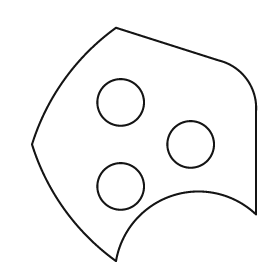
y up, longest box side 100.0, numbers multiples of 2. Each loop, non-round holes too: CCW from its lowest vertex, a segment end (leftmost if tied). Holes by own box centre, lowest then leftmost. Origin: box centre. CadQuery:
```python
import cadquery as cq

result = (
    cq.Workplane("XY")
    .moveTo(-12.0, -50.0)
    .threePointArc((12.0, -22.0), (48.0, -30.0))
    .lineTo(48.0, 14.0)
    .threePointArc((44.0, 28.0), (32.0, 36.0))
    .lineTo(-12.0, 50.0)
    .threePointArc((-34.0, 28.0), (-48.0, 0.0))
    .threePointArc((-34.0, -28.0), (-12.0, -50.0))
    .close()
    .moveTo(-10.0, -18.0)
    .circle(10.0)
    .moveTo(20.0, 0.0)
    .circle(10.0)
    .moveTo(-10.0, 18.0)
    .circle(10.0)
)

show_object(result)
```